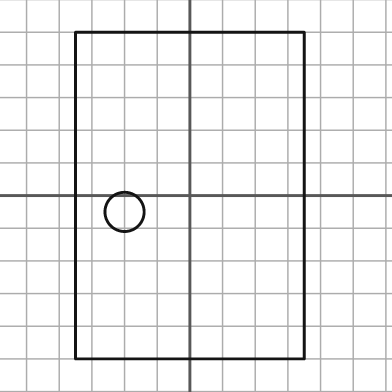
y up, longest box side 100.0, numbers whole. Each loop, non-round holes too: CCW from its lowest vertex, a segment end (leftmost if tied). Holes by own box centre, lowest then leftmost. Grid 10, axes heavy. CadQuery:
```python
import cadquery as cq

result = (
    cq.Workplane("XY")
    .moveTo(-35.0, -50.0)
    .lineTo(35.0, -50.0)
    .lineTo(35.0, 50.0)
    .lineTo(-35.0, 50.0)
    .close()
    .moveTo(-20.0, -5.0)
    .circle(6.0)
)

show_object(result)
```